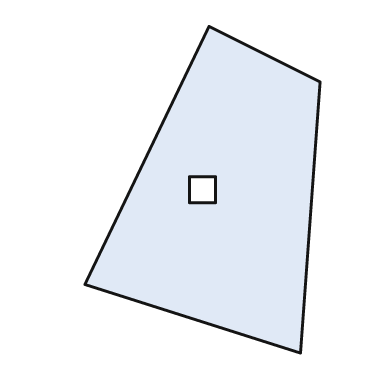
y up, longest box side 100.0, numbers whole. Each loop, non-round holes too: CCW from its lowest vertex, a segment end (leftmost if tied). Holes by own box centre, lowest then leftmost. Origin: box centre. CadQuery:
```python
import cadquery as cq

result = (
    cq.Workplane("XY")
    .moveTo(30.0, -50.0)
    .lineTo(36.0, 33.0)
    .lineTo(2.0, 50.0)
    .lineTo(-36.0, -29.0)
    .close()
    .moveTo(-4.0, -4.0)
    .lineTo(4.0, -4.0)
    .lineTo(4.0, 4.0)
    .lineTo(-4.0, 4.0)
    .close()
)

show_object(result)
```